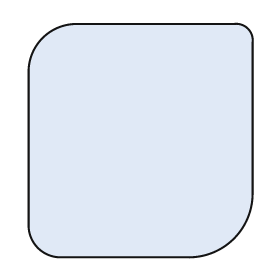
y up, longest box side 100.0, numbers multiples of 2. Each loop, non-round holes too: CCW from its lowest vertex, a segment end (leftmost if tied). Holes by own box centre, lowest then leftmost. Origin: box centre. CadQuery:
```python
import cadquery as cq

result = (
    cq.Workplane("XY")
    .moveTo(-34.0, -50.0)
    .lineTo(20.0, -50.0)
    .threePointArc((40.0, -42.0), (48.0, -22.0))
    .lineTo(48.0, 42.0)
    .threePointArc((46.0, 48.0), (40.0, 50.0))
    .lineTo(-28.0, 50.0)
    .threePointArc((-42.0, 44.0), (-48.0, 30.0))
    .lineTo(-48.0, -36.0)
    .threePointArc((-44.0, -46.0), (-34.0, -50.0))
    .close()
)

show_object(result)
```